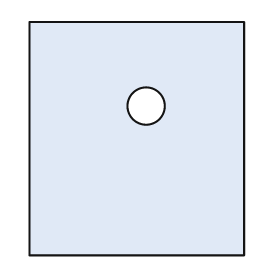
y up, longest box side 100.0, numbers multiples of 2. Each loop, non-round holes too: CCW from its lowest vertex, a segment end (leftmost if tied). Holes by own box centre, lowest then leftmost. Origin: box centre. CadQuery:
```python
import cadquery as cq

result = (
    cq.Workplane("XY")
    .moveTo(-46.0, -50.0)
    .lineTo(46.0, -50.0)
    .lineTo(46.0, 50.0)
    .lineTo(-46.0, 50.0)
    .close()
    .moveTo(4.0, 14.0)
    .circle(8.0)
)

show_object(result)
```